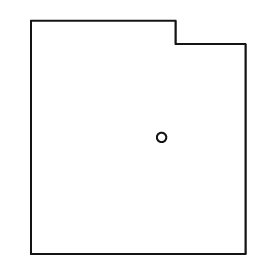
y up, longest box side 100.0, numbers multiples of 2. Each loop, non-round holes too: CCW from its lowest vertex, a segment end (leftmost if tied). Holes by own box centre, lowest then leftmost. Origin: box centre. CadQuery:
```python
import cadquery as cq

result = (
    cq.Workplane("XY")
    .moveTo(-46.0, -50.0)
    .lineTo(46.0, -50.0)
    .lineTo(46.0, 40.0)
    .lineTo(16.0, 40.0)
    .lineTo(16.0, 50.0)
    .lineTo(-46.0, 50.0)
    .close()
    .moveTo(10.0, 0.0)
    .circle(2.0)
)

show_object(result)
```